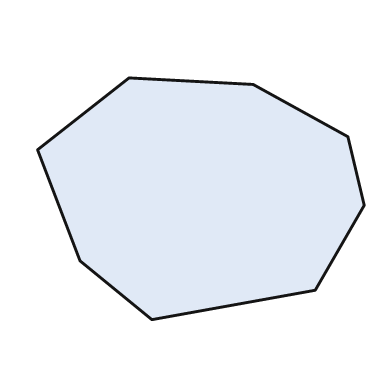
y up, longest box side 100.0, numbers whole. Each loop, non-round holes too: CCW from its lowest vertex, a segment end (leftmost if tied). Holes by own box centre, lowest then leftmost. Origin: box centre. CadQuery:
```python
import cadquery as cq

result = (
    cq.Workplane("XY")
    .moveTo(-15.0, -37.0)
    .lineTo(35.0, -28.0)
    .lineTo(50.0, -2.0)
    .lineTo(45.0, 19.0)
    .lineTo(16.0, 35.0)
    .lineTo(-22.0, 37.0)
    .lineTo(-50.0, 15.0)
    .lineTo(-37.0, -19.0)
    .close()
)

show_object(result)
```